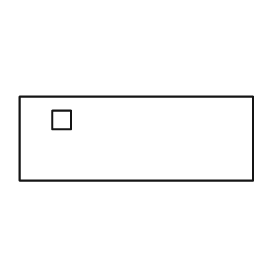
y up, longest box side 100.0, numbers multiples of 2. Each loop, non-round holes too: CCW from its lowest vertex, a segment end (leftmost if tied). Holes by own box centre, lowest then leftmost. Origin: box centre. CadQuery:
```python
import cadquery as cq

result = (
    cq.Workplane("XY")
    .moveTo(-50.0, -18.0)
    .lineTo(50.0, -18.0)
    .lineTo(50.0, 18.0)
    .lineTo(-50.0, 18.0)
    .close()
    .moveTo(-36.0, 4.0)
    .lineTo(-28.0, 4.0)
    .lineTo(-28.0, 12.0)
    .lineTo(-36.0, 12.0)
    .close()
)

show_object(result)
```